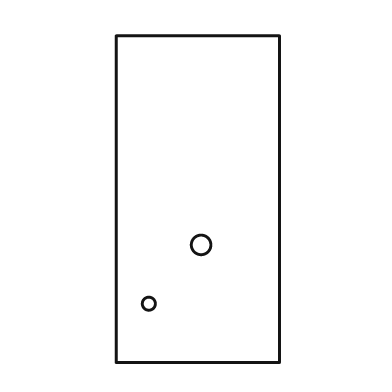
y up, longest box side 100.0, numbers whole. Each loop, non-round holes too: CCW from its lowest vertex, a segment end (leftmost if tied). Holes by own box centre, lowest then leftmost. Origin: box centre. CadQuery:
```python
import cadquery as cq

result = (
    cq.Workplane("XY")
    .moveTo(-25.0, -50.0)
    .lineTo(25.0, -50.0)
    .lineTo(25.0, 50.0)
    .lineTo(-25.0, 50.0)
    .close()
    .moveTo(-15.0, -32.0)
    .circle(2.0)
    .moveTo(1.0, -14.0)
    .circle(3.0)
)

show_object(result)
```